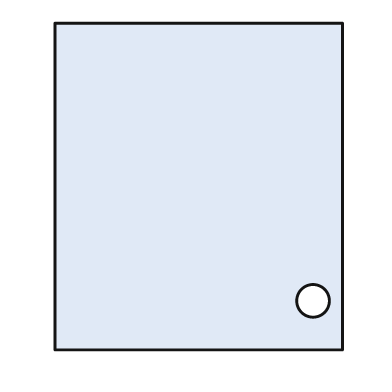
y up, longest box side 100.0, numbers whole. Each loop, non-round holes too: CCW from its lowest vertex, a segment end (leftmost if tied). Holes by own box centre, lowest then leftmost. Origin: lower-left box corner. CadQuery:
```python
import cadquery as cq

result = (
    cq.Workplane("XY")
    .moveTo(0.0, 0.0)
    .lineTo(88.0, 0.0)
    .lineTo(88.0, 100.0)
    .lineTo(0.0, 100.0)
    .close()
    .moveTo(79.0, 15.0)
    .circle(5.0)
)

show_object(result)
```